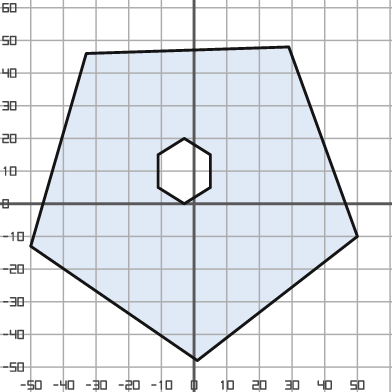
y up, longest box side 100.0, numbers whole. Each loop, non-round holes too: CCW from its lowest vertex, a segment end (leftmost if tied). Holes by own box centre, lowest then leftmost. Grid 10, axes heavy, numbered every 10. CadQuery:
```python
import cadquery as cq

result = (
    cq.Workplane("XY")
    .moveTo(1.0, -48.0)
    .lineTo(50.0, -10.0)
    .lineTo(29.0, 48.0)
    .lineTo(-33.0, 46.0)
    .lineTo(-50.0, -13.0)
    .close()
    .moveTo(-3.0, 0.0)
    .lineTo(5.0, 5.0)
    .lineTo(5.0, 15.0)
    .lineTo(-3.0, 20.0)
    .lineTo(-11.0, 15.0)
    .lineTo(-11.0, 5.0)
    .close()
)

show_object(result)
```